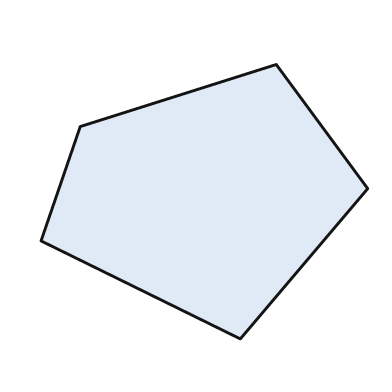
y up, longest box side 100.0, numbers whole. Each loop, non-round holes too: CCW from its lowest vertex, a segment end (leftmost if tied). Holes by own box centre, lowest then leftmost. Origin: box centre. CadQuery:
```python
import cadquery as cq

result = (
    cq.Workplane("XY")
    .moveTo(11.0, -42.0)
    .lineTo(50.0, 4.0)
    .lineTo(22.0, 42.0)
    .lineTo(-38.0, 23.0)
    .lineTo(-50.0, -12.0)
    .close()
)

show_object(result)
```